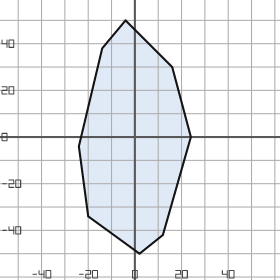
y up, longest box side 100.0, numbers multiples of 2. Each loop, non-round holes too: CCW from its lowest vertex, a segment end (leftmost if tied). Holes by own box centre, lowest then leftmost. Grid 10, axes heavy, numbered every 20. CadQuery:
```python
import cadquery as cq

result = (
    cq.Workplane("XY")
    .moveTo(2.0, -50.0)
    .lineTo(12.0, -42.0)
    .lineTo(24.0, 0.0)
    .lineTo(16.0, 30.0)
    .lineTo(-4.0, 50.0)
    .lineTo(-14.0, 38.0)
    .lineTo(-24.0, -4.0)
    .lineTo(-20.0, -34.0)
    .close()
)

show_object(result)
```